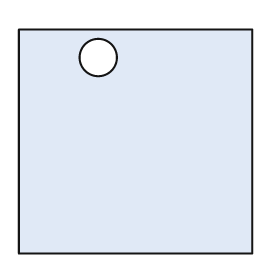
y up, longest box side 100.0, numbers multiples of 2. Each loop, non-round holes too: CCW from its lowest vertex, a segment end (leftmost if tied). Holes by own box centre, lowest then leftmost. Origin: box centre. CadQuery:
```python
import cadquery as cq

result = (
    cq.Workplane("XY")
    .moveTo(-50.0, -48.0)
    .lineTo(50.0, -48.0)
    .lineTo(50.0, 48.0)
    .lineTo(-50.0, 48.0)
    .close()
    .moveTo(-16.0, 36.0)
    .circle(8.0)
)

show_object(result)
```